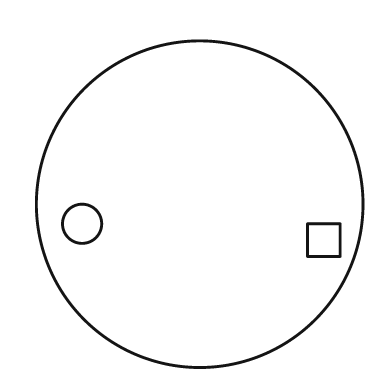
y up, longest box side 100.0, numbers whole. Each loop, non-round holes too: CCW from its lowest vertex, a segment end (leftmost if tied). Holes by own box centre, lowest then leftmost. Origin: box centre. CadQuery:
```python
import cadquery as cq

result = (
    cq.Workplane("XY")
    .moveTo(0.0, 0.0)
    .circle(50.0)
    .moveTo(33.0, -16.0)
    .lineTo(43.0, -16.0)
    .lineTo(43.0, -6.0)
    .lineTo(33.0, -6.0)
    .close()
    .moveTo(-36.0, -6.0)
    .circle(6.0)
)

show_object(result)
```